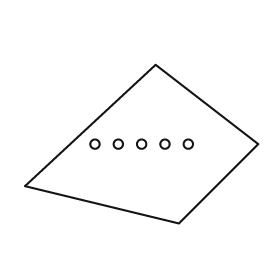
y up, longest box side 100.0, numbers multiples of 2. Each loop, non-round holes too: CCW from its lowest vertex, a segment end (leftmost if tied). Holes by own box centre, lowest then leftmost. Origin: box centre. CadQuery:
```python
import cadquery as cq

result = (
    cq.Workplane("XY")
    .moveTo(16.0, -34.0)
    .lineTo(50.0, 0.0)
    .lineTo(6.0, 34.0)
    .lineTo(-50.0, -18.0)
    .close()
    .moveTo(-20.0, 0.0)
    .circle(2.0)
    .moveTo(-10.0, 0.0)
    .circle(2.0)
    .moveTo(0.0, 0.0)
    .circle(2.0)
    .moveTo(10.0, 0.0)
    .circle(2.0)
    .moveTo(20.0, 0.0)
    .circle(2.0)
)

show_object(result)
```